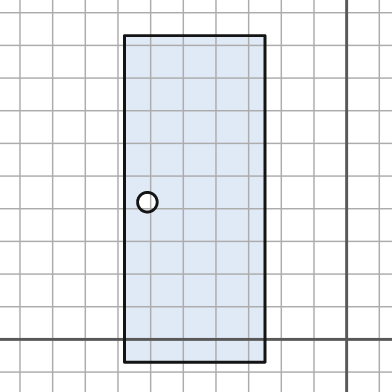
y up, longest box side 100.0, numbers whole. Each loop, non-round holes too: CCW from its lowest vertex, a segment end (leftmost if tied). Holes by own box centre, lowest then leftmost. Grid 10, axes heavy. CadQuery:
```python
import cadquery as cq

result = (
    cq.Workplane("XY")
    .moveTo(-68.0, -7.0)
    .lineTo(-25.0, -7.0)
    .lineTo(-25.0, 93.0)
    .lineTo(-68.0, 93.0)
    .close()
    .moveTo(-61.0, 42.0)
    .circle(3.0)
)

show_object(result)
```